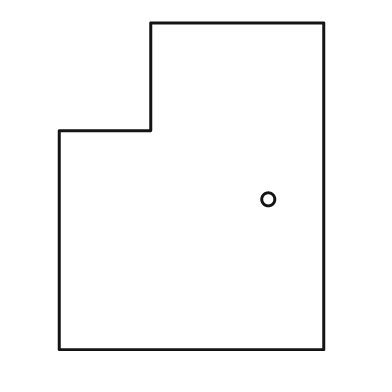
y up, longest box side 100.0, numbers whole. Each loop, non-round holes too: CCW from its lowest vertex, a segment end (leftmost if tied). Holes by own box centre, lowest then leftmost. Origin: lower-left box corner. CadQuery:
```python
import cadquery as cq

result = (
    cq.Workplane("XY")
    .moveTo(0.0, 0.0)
    .lineTo(81.0, 0.0)
    .lineTo(81.0, 100.0)
    .lineTo(28.0, 100.0)
    .lineTo(28.0, 67.0)
    .lineTo(0.0, 67.0)
    .close()
    .moveTo(64.0, 46.0)
    .circle(2.0)
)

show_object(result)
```